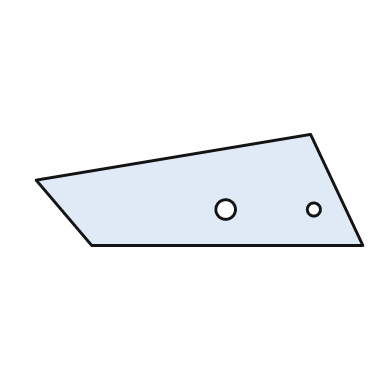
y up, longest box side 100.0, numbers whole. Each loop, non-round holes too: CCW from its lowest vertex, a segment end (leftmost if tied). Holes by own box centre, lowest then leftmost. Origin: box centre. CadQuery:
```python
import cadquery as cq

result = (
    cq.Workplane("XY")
    .moveTo(-33.0, -17.0)
    .lineTo(50.0, -17.0)
    .lineTo(34.0, 17.0)
    .lineTo(-50.0, 3.0)
    .close()
    .moveTo(8.0, -6.0)
    .circle(3.0)
    .moveTo(35.0, -6.0)
    .circle(2.0)
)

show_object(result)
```